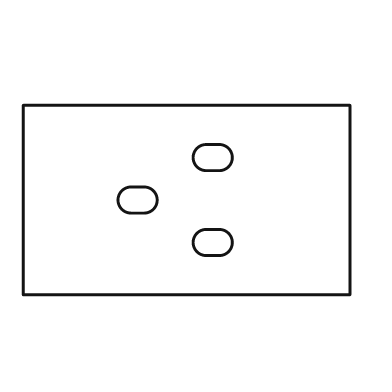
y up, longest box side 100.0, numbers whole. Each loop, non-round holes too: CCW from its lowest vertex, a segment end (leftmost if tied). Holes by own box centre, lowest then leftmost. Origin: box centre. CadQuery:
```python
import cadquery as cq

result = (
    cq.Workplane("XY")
    .moveTo(-50.0, -29.0)
    .lineTo(50.0, -29.0)
    .lineTo(50.0, 29.0)
    .lineTo(-50.0, 29.0)
    .close()
    .moveTo(6.0, -17.0)
    .lineTo(10.0, -17.0)
    .threePointArc((14.0, -13.0), (10.0, -9.0))
    .lineTo(6.0, -9.0)
    .threePointArc((2.0, -13.0), (6.0, -17.0))
    .close()
    .moveTo(-17.0, -4.0)
    .lineTo(-13.0, -4.0)
    .threePointArc((-9.0, 0.0), (-13.0, 4.0))
    .lineTo(-17.0, 4.0)
    .threePointArc((-21.0, 0.0), (-17.0, -4.0))
    .close()
    .moveTo(6.0, 9.0)
    .lineTo(10.0, 9.0)
    .threePointArc((14.0, 13.0), (10.0, 17.0))
    .lineTo(6.0, 17.0)
    .threePointArc((2.0, 13.0), (6.0, 9.0))
    .close()
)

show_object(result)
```